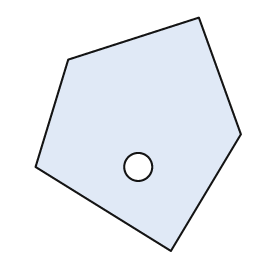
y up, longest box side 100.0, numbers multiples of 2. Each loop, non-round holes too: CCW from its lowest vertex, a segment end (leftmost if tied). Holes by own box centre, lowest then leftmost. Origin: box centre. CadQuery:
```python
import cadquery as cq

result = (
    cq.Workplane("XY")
    .moveTo(14.0, -50.0)
    .lineTo(44.0, 0.0)
    .lineTo(26.0, 50.0)
    .lineTo(-30.0, 32.0)
    .lineTo(-44.0, -14.0)
    .close()
    .moveTo(0.0, -14.0)
    .circle(6.0)
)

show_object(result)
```